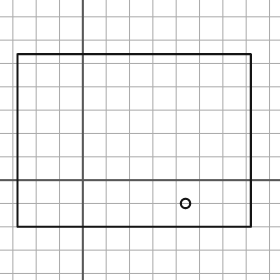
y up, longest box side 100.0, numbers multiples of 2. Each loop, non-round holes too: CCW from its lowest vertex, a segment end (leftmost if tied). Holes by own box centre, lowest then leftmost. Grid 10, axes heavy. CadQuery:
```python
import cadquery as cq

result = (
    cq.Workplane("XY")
    .moveTo(-28.0, -20.0)
    .lineTo(72.0, -20.0)
    .lineTo(72.0, 54.0)
    .lineTo(-28.0, 54.0)
    .close()
    .moveTo(44.0, -10.0)
    .circle(2.0)
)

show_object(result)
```